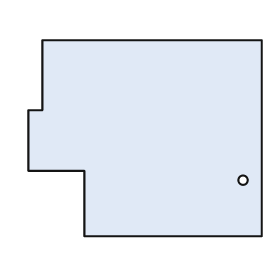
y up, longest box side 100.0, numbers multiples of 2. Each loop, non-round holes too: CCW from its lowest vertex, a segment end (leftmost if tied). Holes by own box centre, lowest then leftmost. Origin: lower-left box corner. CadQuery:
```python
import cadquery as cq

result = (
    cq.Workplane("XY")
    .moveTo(24.0, 0.0)
    .lineTo(100.0, 0.0)
    .lineTo(100.0, 84.0)
    .lineTo(6.0, 84.0)
    .lineTo(6.0, 54.0)
    .lineTo(0.0, 54.0)
    .lineTo(0.0, 28.0)
    .lineTo(24.0, 28.0)
    .close()
    .moveTo(92.0, 24.0)
    .circle(2.0)
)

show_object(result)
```